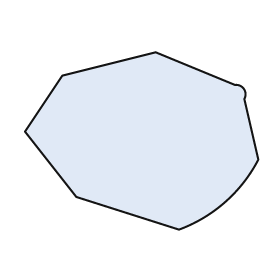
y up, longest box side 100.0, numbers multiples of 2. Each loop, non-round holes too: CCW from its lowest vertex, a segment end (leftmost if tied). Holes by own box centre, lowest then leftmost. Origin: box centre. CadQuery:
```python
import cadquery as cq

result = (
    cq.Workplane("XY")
    .moveTo(16.0, -38.0)
    .threePointArc((36.0, -26.0), (50.0, -8.0))
    .lineTo(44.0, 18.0)
    .threePointArc((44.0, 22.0), (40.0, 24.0))
    .lineTo(6.0, 38.0)
    .lineTo(-34.0, 28.0)
    .lineTo(-50.0, 4.0)
    .lineTo(-28.0, -24.0)
    .close()
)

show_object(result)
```